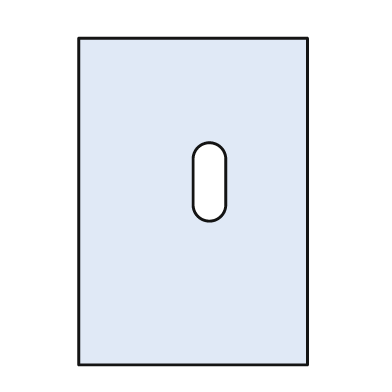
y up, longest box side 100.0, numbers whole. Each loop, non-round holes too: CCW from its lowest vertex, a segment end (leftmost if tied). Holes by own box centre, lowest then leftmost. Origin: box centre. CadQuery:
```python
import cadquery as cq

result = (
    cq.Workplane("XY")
    .moveTo(-35.0, -50.0)
    .lineTo(35.0, -50.0)
    .lineTo(35.0, 50.0)
    .lineTo(-35.0, 50.0)
    .close()
    .moveTo(0.0, -1.0)
    .threePointArc((5.0, -6.0), (10.0, -1.0))
    .lineTo(10.0, 13.0)
    .threePointArc((5.0, 18.0), (0.0, 13.0))
    .close()
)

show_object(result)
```